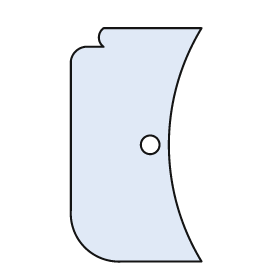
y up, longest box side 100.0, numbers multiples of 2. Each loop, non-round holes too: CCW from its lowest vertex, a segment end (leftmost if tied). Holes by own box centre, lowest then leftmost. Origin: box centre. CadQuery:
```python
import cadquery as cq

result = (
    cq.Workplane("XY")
    .moveTo(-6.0, -50.0)
    .lineTo(28.0, -50.0)
    .threePointArc((14.0, 0.0), (28.0, 50.0))
    .lineTo(-14.0, 50.0)
    .threePointArc((-16.0, 46.0), (-14.0, 42.0))
    .lineTo(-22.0, 42.0)
    .threePointArc((-26.0, 40.0), (-28.0, 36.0))
    .lineTo(-28.0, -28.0)
    .threePointArc((-22.0, -44.0), (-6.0, -50.0))
    .close()
    .moveTo(6.0, 0.0)
    .circle(4.0)
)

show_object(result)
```